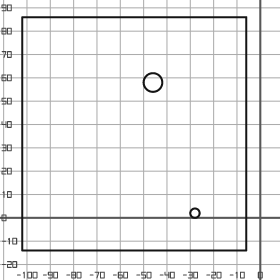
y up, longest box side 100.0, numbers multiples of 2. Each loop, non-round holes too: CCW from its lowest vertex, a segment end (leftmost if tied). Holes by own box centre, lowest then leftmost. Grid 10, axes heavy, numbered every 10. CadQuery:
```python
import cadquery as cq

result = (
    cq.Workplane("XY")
    .moveTo(-102.0, -14.0)
    .lineTo(-6.0, -14.0)
    .lineTo(-6.0, 86.0)
    .lineTo(-102.0, 86.0)
    .close()
    .moveTo(-28.0, 2.0)
    .circle(2.0)
    .moveTo(-46.0, 58.0)
    .circle(4.0)
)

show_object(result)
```